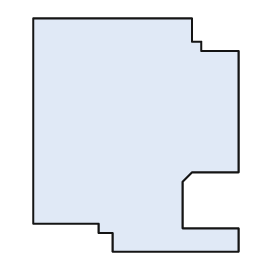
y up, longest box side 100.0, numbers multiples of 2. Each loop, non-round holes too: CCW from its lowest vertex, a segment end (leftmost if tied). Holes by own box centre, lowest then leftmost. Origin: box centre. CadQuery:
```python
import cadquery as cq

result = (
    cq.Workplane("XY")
    .moveTo(-10.0, -50.0)
    .lineTo(44.0, -50.0)
    .lineTo(44.0, -40.0)
    .lineTo(20.0, -40.0)
    .lineTo(20.0, -20.0)
    .lineTo(24.0, -16.0)
    .lineTo(44.0, -16.0)
    .lineTo(44.0, 36.0)
    .lineTo(28.0, 36.0)
    .lineTo(28.0, 40.0)
    .lineTo(24.0, 40.0)
    .lineTo(24.0, 50.0)
    .lineTo(-44.0, 50.0)
    .lineTo(-44.0, -38.0)
    .lineTo(-16.0, -38.0)
    .lineTo(-16.0, -42.0)
    .lineTo(-10.0, -42.0)
    .close()
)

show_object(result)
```